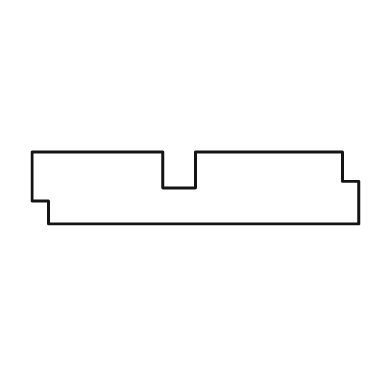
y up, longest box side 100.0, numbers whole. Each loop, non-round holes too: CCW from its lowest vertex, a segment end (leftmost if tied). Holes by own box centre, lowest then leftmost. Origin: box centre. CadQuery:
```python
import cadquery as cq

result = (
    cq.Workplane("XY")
    .moveTo(-45.0, -11.0)
    .lineTo(50.0, -11.0)
    .lineTo(50.0, 2.0)
    .lineTo(45.0, 2.0)
    .lineTo(45.0, 11.0)
    .lineTo(0.0, 11.0)
    .lineTo(0.0, 0.0)
    .lineTo(-10.0, 0.0)
    .lineTo(-10.0, 11.0)
    .lineTo(-50.0, 11.0)
    .lineTo(-50.0, -4.0)
    .lineTo(-45.0, -4.0)
    .close()
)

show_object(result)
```